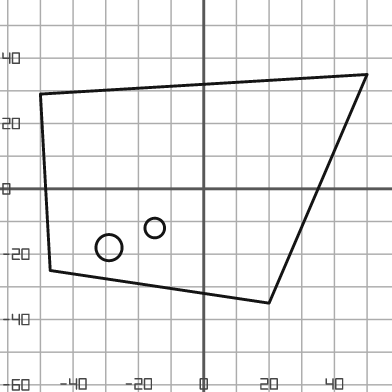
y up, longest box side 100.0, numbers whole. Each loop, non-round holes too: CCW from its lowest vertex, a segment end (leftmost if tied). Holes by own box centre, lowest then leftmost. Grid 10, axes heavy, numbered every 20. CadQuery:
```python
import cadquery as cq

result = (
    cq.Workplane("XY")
    .moveTo(20.0, -35.0)
    .lineTo(50.0, 35.0)
    .lineTo(-50.0, 29.0)
    .lineTo(-47.0, -25.0)
    .close()
    .moveTo(-29.0, -18.0)
    .circle(4.0)
    .moveTo(-15.0, -12.0)
    .circle(3.0)
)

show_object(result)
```